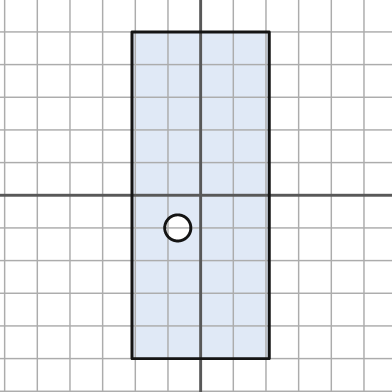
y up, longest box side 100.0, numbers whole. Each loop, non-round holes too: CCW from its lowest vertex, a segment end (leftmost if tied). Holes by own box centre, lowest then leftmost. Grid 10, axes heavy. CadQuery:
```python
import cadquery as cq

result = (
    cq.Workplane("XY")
    .moveTo(-21.0, -50.0)
    .lineTo(21.0, -50.0)
    .lineTo(21.0, 50.0)
    .lineTo(-21.0, 50.0)
    .close()
    .moveTo(-7.0, -10.0)
    .circle(4.0)
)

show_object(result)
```